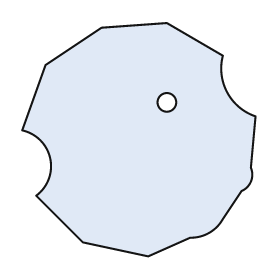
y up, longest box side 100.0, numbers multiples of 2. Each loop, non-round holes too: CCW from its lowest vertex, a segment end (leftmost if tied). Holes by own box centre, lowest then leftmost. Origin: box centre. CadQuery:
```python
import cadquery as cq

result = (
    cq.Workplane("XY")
    .moveTo(4.0, -50.0)
    .lineTo(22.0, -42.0)
    .threePointArc((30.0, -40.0), (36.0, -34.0))
    .lineTo(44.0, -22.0)
    .threePointArc((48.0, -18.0), (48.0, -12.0))
    .lineTo(50.0, 10.0)
    .threePointArc((38.0, 20.0), (36.0, 36.0))
    .lineTo(12.0, 50.0)
    .lineTo(-16.0, 48.0)
    .lineTo(-40.0, 32.0)
    .lineTo(-50.0, 4.0)
    .threePointArc((-38.0, -8.0), (-44.0, -24.0))
    .lineTo(-24.0, -44.0)
    .close()
    .moveTo(12.0, 16.0)
    .circle(4.0)
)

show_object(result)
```